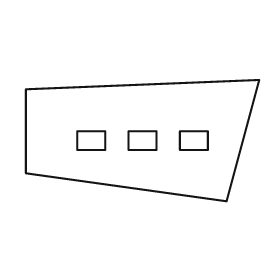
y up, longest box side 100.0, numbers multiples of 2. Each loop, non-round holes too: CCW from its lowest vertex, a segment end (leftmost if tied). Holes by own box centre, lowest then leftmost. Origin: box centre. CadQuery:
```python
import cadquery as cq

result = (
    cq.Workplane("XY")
    .moveTo(36.0, -26.0)
    .lineTo(50.0, 26.0)
    .lineTo(-50.0, 22.0)
    .lineTo(-50.0, -14.0)
    .close()
    .moveTo(-28.0, -4.0)
    .lineTo(-16.0, -4.0)
    .lineTo(-16.0, 4.0)
    .lineTo(-28.0, 4.0)
    .close()
    .moveTo(-6.0, -4.0)
    .lineTo(6.0, -4.0)
    .lineTo(6.0, 4.0)
    .lineTo(-6.0, 4.0)
    .close()
    .moveTo(16.0, -4.0)
    .lineTo(28.0, -4.0)
    .lineTo(28.0, 4.0)
    .lineTo(16.0, 4.0)
    .close()
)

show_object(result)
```